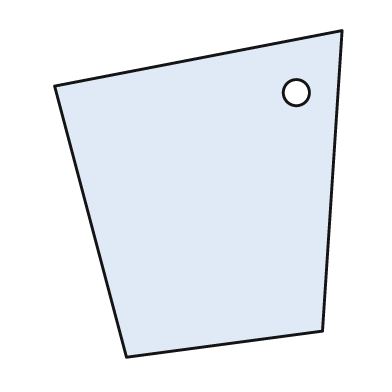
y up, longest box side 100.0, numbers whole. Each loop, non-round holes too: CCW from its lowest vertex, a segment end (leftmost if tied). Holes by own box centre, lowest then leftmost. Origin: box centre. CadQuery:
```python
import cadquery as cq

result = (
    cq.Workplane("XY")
    .moveTo(-22.0, -50.0)
    .lineTo(38.0, -42.0)
    .lineTo(44.0, 50.0)
    .lineTo(-44.0, 33.0)
    .close()
    .moveTo(30.0, 31.0)
    .circle(4.0)
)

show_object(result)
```